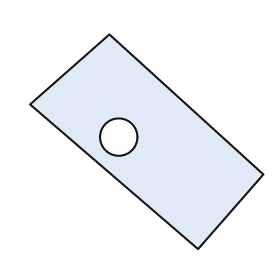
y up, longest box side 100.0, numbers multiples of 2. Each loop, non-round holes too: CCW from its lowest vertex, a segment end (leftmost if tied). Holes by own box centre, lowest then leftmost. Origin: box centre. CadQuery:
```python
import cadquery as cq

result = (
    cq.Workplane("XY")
    .moveTo(22.0, -46.0)
    .lineTo(50.0, -14.0)
    .lineTo(-16.0, 46.0)
    .lineTo(-50.0, 16.0)
    .close()
    .moveTo(-12.0, 2.0)
    .circle(8.0)
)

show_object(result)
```